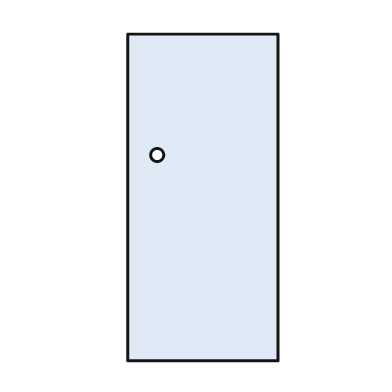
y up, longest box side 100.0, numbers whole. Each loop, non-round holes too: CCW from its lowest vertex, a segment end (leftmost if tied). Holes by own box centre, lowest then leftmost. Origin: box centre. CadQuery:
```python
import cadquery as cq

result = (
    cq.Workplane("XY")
    .moveTo(-23.0, -50.0)
    .lineTo(23.0, -50.0)
    .lineTo(23.0, 50.0)
    .lineTo(-23.0, 50.0)
    .close()
    .moveTo(-14.0, 13.0)
    .circle(2.0)
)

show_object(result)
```